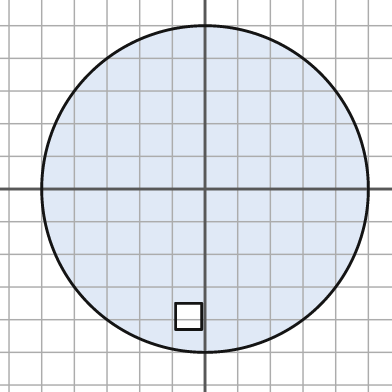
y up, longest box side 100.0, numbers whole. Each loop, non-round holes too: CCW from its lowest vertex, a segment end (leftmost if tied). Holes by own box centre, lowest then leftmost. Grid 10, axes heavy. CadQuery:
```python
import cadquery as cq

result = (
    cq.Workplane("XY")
    .moveTo(0.0, 0.0)
    .circle(50.0)
    .moveTo(-9.0, -43.0)
    .lineTo(-1.0, -43.0)
    .lineTo(-1.0, -35.0)
    .lineTo(-9.0, -35.0)
    .close()
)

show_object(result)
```